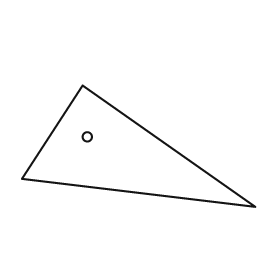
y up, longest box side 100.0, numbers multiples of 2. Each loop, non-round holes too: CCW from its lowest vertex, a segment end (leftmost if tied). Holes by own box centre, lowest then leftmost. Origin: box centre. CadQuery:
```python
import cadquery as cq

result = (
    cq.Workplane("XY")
    .moveTo(50.0, -26.0)
    .lineTo(-24.0, 26.0)
    .lineTo(-50.0, -14.0)
    .close()
    .moveTo(-22.0, 4.0)
    .circle(2.0)
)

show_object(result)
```